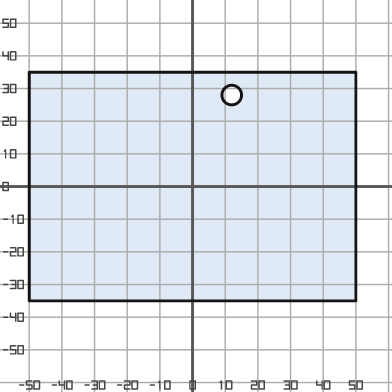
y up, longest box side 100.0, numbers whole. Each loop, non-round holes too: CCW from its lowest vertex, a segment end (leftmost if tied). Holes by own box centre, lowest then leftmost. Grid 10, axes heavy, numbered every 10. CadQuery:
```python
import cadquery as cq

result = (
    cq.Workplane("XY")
    .moveTo(-50.0, -35.0)
    .lineTo(50.0, -35.0)
    .lineTo(50.0, 35.0)
    .lineTo(-50.0, 35.0)
    .close()
    .moveTo(12.0, 28.0)
    .circle(3.0)
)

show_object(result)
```